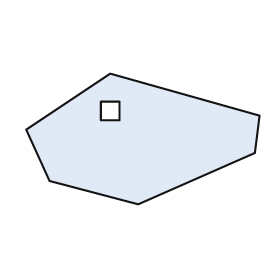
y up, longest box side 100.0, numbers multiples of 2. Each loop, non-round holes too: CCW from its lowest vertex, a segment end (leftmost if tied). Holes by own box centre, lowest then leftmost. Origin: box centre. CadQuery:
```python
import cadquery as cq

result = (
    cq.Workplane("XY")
    .moveTo(-2.0, -28.0)
    .lineTo(48.0, -6.0)
    .lineTo(50.0, 10.0)
    .lineTo(-14.0, 28.0)
    .lineTo(-50.0, 4.0)
    .lineTo(-40.0, -18.0)
    .close()
    .moveTo(-18.0, 8.0)
    .lineTo(-10.0, 8.0)
    .lineTo(-10.0, 16.0)
    .lineTo(-18.0, 16.0)
    .close()
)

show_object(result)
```